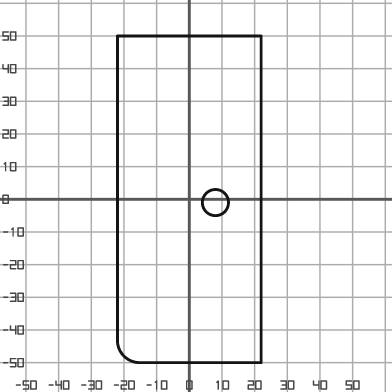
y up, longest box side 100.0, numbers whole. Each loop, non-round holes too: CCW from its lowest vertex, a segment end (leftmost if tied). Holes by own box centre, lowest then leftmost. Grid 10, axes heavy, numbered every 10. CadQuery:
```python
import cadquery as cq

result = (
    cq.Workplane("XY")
    .moveTo(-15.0, -50.0)
    .lineTo(22.0, -50.0)
    .lineTo(22.0, 50.0)
    .lineTo(-22.0, 50.0)
    .lineTo(-22.0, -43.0)
    .threePointArc((-20.0, -48.0), (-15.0, -50.0))
    .close()
    .moveTo(8.0, -1.0)
    .circle(4.0)
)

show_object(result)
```